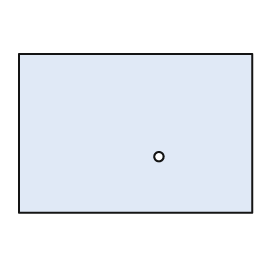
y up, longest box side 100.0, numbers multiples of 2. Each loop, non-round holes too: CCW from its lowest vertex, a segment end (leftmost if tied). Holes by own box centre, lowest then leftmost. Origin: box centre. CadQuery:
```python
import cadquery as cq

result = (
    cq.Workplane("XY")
    .moveTo(-50.0, -34.0)
    .lineTo(50.0, -34.0)
    .lineTo(50.0, 34.0)
    .lineTo(-50.0, 34.0)
    .close()
    .moveTo(10.0, -10.0)
    .circle(2.0)
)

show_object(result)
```